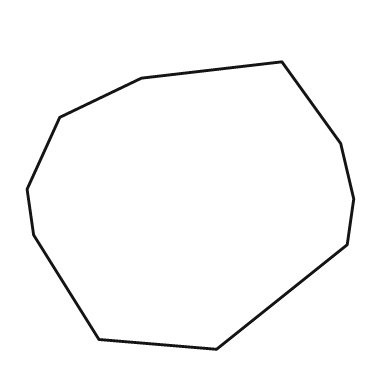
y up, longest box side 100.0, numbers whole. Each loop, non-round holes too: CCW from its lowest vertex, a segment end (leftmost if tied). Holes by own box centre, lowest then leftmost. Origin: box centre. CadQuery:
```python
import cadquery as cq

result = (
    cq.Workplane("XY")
    .moveTo(8.0, -44.0)
    .lineTo(48.0, -12.0)
    .lineTo(50.0, 2.0)
    .lineTo(46.0, 19.0)
    .lineTo(28.0, 44.0)
    .lineTo(-15.0, 39.0)
    .lineTo(-40.0, 27.0)
    .lineTo(-50.0, 5.0)
    .lineTo(-48.0, -9.0)
    .lineTo(-28.0, -41.0)
    .close()
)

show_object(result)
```